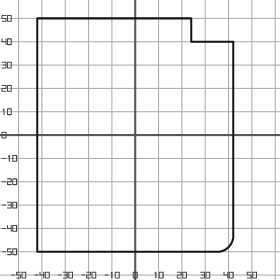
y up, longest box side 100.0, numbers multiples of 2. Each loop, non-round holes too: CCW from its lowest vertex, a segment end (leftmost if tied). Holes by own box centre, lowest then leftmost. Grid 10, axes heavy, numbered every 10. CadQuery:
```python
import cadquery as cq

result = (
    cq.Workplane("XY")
    .moveTo(-42.0, -50.0)
    .lineTo(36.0, -50.0)
    .threePointArc((40.0, -48.0), (42.0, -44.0))
    .lineTo(42.0, 40.0)
    .lineTo(24.0, 40.0)
    .lineTo(24.0, 50.0)
    .lineTo(-42.0, 50.0)
    .close()
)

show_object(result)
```